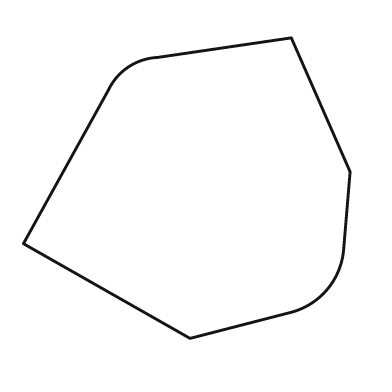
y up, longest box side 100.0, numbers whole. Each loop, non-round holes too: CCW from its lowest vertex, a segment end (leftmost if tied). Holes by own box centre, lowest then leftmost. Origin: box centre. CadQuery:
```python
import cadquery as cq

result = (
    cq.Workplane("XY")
    .moveTo(1.0, -46.0)
    .lineTo(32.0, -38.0)
    .threePointArc((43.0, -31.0), (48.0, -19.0))
    .lineTo(50.0, 5.0)
    .lineTo(32.0, 46.0)
    .lineTo(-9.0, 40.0)
    .threePointArc((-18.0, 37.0), (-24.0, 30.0))
    .lineTo(-50.0, -17.0)
    .close()
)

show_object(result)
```